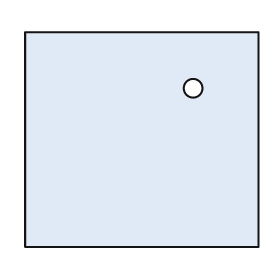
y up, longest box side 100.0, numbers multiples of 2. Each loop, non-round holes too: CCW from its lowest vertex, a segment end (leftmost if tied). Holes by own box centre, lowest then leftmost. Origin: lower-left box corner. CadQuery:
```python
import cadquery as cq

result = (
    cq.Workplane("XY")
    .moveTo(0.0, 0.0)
    .lineTo(100.0, 0.0)
    .lineTo(100.0, 92.0)
    .lineTo(0.0, 92.0)
    .close()
    .moveTo(72.0, 68.0)
    .circle(4.0)
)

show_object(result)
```